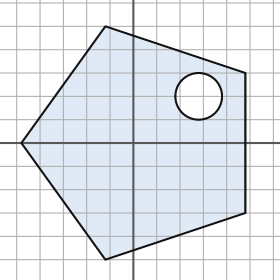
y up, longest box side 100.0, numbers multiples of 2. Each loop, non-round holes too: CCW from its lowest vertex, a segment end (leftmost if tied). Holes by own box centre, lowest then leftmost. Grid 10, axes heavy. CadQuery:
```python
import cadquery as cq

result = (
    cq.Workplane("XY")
    .moveTo(-12.0, -50.0)
    .lineTo(48.0, -30.0)
    .lineTo(48.0, 30.0)
    .lineTo(-12.0, 50.0)
    .lineTo(-48.0, 0.0)
    .close()
    .moveTo(28.0, 20.0)
    .circle(10.0)
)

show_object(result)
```